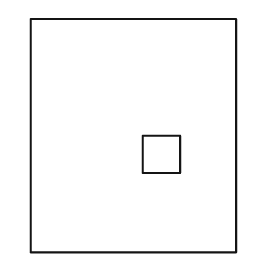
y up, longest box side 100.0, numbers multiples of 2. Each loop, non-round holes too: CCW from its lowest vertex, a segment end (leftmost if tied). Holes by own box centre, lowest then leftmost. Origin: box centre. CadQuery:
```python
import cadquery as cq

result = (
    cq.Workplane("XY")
    .moveTo(-44.0, -50.0)
    .lineTo(44.0, -50.0)
    .lineTo(44.0, 50.0)
    .lineTo(-44.0, 50.0)
    .close()
    .moveTo(4.0, -16.0)
    .lineTo(20.0, -16.0)
    .lineTo(20.0, 0.0)
    .lineTo(4.0, 0.0)
    .close()
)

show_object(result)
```